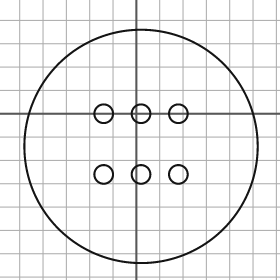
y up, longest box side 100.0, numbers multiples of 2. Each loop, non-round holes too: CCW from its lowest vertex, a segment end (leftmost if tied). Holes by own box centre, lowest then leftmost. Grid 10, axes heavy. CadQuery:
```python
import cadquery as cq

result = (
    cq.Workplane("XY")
    .moveTo(2.0, -14.0)
    .circle(50.0)
    .moveTo(-14.0, -26.0)
    .circle(4.0)
    .moveTo(2.0, -26.0)
    .circle(4.0)
    .moveTo(18.0, -26.0)
    .circle(4.0)
    .moveTo(-14.0, 0.0)
    .circle(4.0)
    .moveTo(2.0, 0.0)
    .circle(4.0)
    .moveTo(18.0, 0.0)
    .circle(4.0)
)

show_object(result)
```